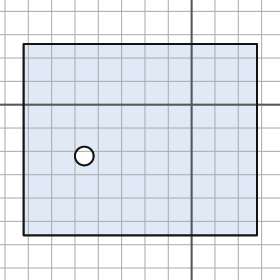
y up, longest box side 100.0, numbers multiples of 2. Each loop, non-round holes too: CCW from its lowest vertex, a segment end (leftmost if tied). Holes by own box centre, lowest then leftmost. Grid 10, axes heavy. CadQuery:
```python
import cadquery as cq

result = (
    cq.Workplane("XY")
    .moveTo(-72.0, -56.0)
    .lineTo(28.0, -56.0)
    .lineTo(28.0, 26.0)
    .lineTo(-72.0, 26.0)
    .close()
    .moveTo(-46.0, -22.0)
    .circle(4.0)
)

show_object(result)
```